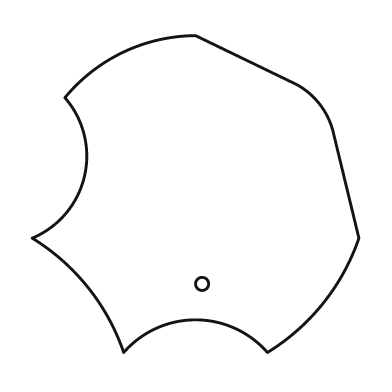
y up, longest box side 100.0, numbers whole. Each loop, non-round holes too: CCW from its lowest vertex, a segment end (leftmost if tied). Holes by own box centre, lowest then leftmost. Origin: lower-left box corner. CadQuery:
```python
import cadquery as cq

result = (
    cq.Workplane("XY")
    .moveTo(28.0, 0.0)
    .threePointArc((50.0, 10.0), (72.0, 0.0))
    .threePointArc((89.0, 15.0), (100.0, 35.0))
    .lineTo(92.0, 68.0)
    .threePointArc((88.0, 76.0), (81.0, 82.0))
    .lineTo(50.0, 97.0)
    .threePointArc((28.0, 92.0), (10.0, 78.0))
    .threePointArc((16.0, 54.0), (0.0, 35.0))
    .threePointArc((17.0, 20.0), (28.0, 0.0))
    .close()
    .moveTo(52.0, 21.0)
    .circle(2.0)
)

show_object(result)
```